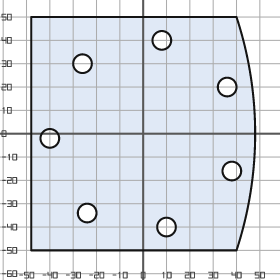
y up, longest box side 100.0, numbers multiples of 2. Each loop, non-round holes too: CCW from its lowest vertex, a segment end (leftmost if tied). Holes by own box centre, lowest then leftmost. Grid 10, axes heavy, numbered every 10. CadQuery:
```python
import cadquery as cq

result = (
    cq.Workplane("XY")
    .moveTo(-48.0, -50.0)
    .lineTo(40.0, -50.0)
    .threePointArc((48.0, 0.0), (40.0, 50.0))
    .lineTo(-48.0, 50.0)
    .close()
    .moveTo(10.0, -40.0)
    .circle(4.0)
    .moveTo(-24.0, -34.0)
    .circle(4.0)
    .moveTo(38.0, -16.0)
    .circle(4.0)
    .moveTo(-40.0, -2.0)
    .circle(4.0)
    .moveTo(36.0, 20.0)
    .circle(4.0)
    .moveTo(-26.0, 30.0)
    .circle(4.0)
    .moveTo(8.0, 40.0)
    .circle(4.0)
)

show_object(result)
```